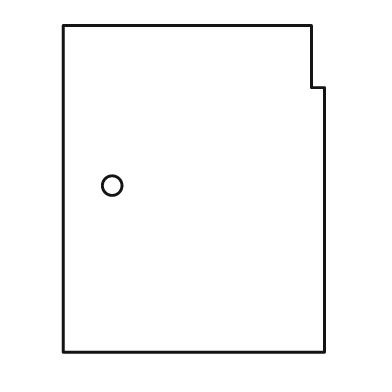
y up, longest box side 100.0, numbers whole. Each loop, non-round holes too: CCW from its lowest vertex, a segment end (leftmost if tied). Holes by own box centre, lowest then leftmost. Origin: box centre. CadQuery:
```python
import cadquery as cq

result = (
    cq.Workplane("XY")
    .moveTo(-40.0, -50.0)
    .lineTo(40.0, -50.0)
    .lineTo(40.0, 31.0)
    .lineTo(36.0, 31.0)
    .lineTo(36.0, 50.0)
    .lineTo(-40.0, 50.0)
    .close()
    .moveTo(-25.0, 1.0)
    .circle(3.0)
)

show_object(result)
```